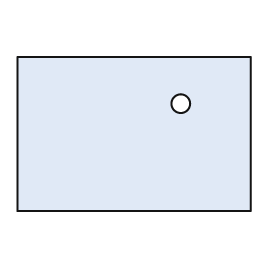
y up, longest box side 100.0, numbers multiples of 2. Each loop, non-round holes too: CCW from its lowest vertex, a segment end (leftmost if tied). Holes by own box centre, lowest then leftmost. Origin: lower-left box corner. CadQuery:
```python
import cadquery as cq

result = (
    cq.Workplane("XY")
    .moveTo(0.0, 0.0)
    .lineTo(100.0, 0.0)
    .lineTo(100.0, 66.0)
    .lineTo(0.0, 66.0)
    .close()
    .moveTo(70.0, 46.0)
    .circle(4.0)
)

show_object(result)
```